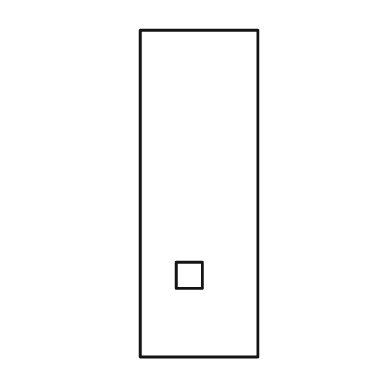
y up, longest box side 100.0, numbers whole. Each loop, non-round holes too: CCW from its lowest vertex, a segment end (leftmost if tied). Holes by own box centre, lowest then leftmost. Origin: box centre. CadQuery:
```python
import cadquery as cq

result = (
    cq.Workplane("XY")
    .moveTo(-18.0, -50.0)
    .lineTo(18.0, -50.0)
    .lineTo(18.0, 50.0)
    .lineTo(-18.0, 50.0)
    .close()
    .moveTo(-7.0, -29.0)
    .lineTo(1.0, -29.0)
    .lineTo(1.0, -21.0)
    .lineTo(-7.0, -21.0)
    .close()
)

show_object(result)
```